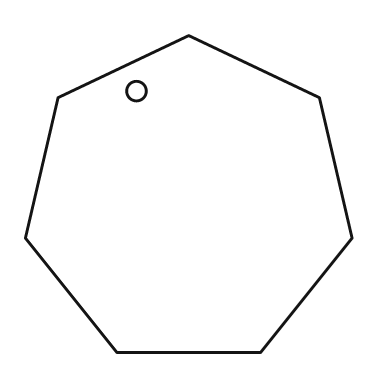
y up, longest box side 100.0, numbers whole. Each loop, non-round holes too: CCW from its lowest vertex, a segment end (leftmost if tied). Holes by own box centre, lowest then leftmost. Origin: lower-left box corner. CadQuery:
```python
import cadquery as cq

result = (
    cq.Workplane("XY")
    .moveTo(28.0, 0.0)
    .lineTo(72.0, 0.0)
    .lineTo(100.0, 35.0)
    .lineTo(90.0, 78.0)
    .lineTo(50.0, 97.0)
    .lineTo(10.0, 78.0)
    .lineTo(0.0, 35.0)
    .close()
    .moveTo(34.0, 80.0)
    .circle(3.0)
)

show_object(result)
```